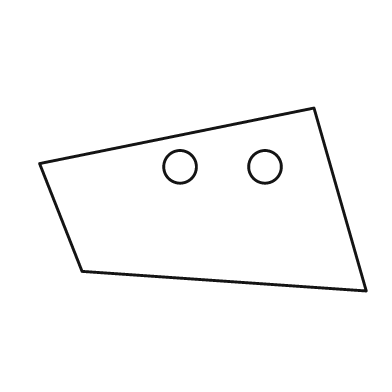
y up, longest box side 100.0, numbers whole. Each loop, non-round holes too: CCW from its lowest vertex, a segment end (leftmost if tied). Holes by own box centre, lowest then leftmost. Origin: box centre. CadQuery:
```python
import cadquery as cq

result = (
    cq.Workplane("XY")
    .moveTo(50.0, -28.0)
    .lineTo(34.0, 28.0)
    .lineTo(-50.0, 11.0)
    .lineTo(-37.0, -22.0)
    .close()
    .moveTo(-7.0, 10.0)
    .circle(5.0)
    .moveTo(19.0, 10.0)
    .circle(5.0)
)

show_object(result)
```